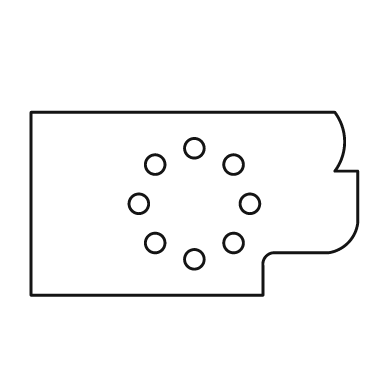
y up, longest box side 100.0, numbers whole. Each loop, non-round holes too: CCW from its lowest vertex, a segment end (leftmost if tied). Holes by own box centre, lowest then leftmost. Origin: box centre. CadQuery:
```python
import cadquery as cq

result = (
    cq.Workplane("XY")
    .moveTo(-50.0, -28.0)
    .lineTo(21.0, -28.0)
    .lineTo(21.0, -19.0)
    .threePointArc((22.0, -16.0), (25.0, -15.0))
    .lineTo(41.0, -15.0)
    .threePointArc((47.0, -12.0), (50.0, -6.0))
    .lineTo(50.0, 10.0)
    .lineTo(43.0, 10.0)
    .threePointArc((46.0, 19.0), (43.0, 28.0))
    .lineTo(-50.0, 28.0)
    .close()
    .moveTo(0.0, -17.0)
    .circle(3.0)
    .moveTo(-12.0, -12.0)
    .circle(3.0)
    .moveTo(12.0, -12.0)
    .circle(3.0)
    .moveTo(-17.0, 0.0)
    .circle(3.0)
    .moveTo(17.0, 0.0)
    .circle(3.0)
    .moveTo(-12.0, 12.0)
    .circle(3.0)
    .moveTo(12.0, 12.0)
    .circle(3.0)
    .moveTo(0.0, 17.0)
    .circle(3.0)
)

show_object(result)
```